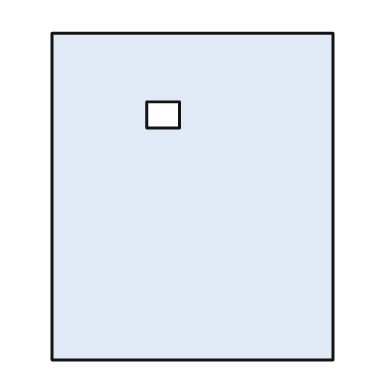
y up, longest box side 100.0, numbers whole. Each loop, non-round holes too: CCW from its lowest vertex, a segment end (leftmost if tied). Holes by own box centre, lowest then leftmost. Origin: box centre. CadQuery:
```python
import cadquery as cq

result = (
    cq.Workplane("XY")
    .moveTo(-43.0, -50.0)
    .lineTo(43.0, -50.0)
    .lineTo(43.0, 50.0)
    .lineTo(-43.0, 50.0)
    .close()
    .moveTo(-14.0, 21.0)
    .lineTo(-4.0, 21.0)
    .lineTo(-4.0, 29.0)
    .lineTo(-14.0, 29.0)
    .close()
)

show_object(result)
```